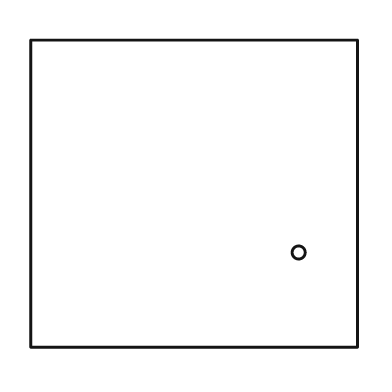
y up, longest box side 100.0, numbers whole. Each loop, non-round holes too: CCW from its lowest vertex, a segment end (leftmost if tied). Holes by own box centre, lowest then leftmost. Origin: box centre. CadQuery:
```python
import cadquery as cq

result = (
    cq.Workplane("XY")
    .moveTo(-50.0, -47.0)
    .lineTo(50.0, -47.0)
    .lineTo(50.0, 47.0)
    .lineTo(-50.0, 47.0)
    .close()
    .moveTo(32.0, -18.0)
    .circle(2.0)
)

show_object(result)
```